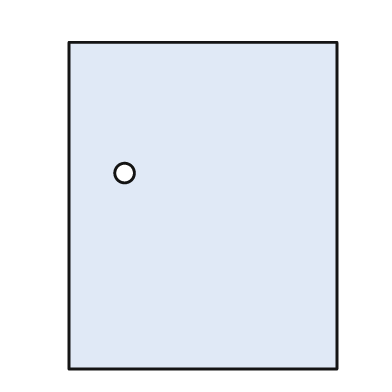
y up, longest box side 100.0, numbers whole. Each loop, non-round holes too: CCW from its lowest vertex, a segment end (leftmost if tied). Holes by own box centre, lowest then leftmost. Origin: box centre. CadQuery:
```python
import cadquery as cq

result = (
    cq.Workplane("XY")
    .moveTo(-41.0, -50.0)
    .lineTo(41.0, -50.0)
    .lineTo(41.0, 50.0)
    .lineTo(-41.0, 50.0)
    .close()
    .moveTo(-24.0, 10.0)
    .circle(3.0)
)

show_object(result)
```